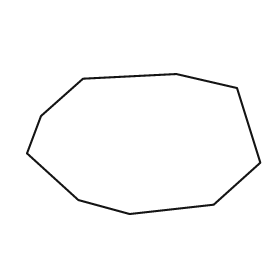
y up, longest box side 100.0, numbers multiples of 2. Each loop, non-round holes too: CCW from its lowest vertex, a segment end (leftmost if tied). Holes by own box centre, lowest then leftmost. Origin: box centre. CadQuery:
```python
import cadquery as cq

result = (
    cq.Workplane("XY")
    .moveTo(-6.0, -30.0)
    .lineTo(30.0, -26.0)
    .lineTo(50.0, -8.0)
    .lineTo(40.0, 24.0)
    .lineTo(14.0, 30.0)
    .lineTo(-26.0, 28.0)
    .lineTo(-44.0, 12.0)
    .lineTo(-50.0, -4.0)
    .lineTo(-28.0, -24.0)
    .close()
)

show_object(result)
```